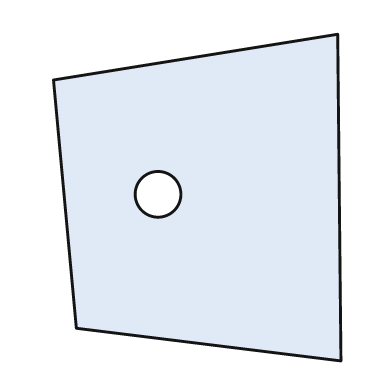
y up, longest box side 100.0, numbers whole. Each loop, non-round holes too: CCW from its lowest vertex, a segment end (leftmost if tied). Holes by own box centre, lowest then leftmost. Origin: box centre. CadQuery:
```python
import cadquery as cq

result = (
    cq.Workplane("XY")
    .moveTo(44.0, -50.0)
    .lineTo(43.0, 50.0)
    .lineTo(-44.0, 36.0)
    .lineTo(-37.0, -40.0)
    .close()
    .moveTo(-12.0, 1.0)
    .circle(7.0)
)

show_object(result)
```